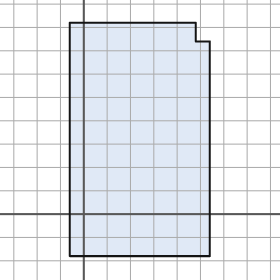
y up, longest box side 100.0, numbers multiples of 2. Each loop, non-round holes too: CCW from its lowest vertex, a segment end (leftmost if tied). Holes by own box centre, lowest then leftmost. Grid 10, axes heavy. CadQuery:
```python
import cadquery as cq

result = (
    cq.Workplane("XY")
    .moveTo(-6.0, -18.0)
    .lineTo(54.0, -18.0)
    .lineTo(54.0, 74.0)
    .lineTo(48.0, 74.0)
    .lineTo(48.0, 82.0)
    .lineTo(-6.0, 82.0)
    .close()
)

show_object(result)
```